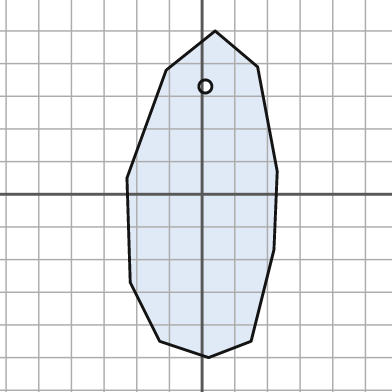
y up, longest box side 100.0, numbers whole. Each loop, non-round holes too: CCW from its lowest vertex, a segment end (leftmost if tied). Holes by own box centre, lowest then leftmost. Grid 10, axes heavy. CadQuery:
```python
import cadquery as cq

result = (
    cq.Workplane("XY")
    .moveTo(2.0, -50.0)
    .lineTo(15.0, -45.0)
    .lineTo(22.0, -17.0)
    .lineTo(23.0, 7.0)
    .lineTo(17.0, 39.0)
    .lineTo(4.0, 50.0)
    .lineTo(-11.0, 38.0)
    .lineTo(-23.0, 5.0)
    .lineTo(-22.0, -27.0)
    .lineTo(-13.0, -45.0)
    .close()
    .moveTo(1.0, 33.0)
    .circle(2.0)
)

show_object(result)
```